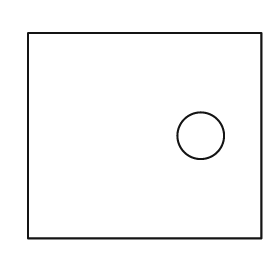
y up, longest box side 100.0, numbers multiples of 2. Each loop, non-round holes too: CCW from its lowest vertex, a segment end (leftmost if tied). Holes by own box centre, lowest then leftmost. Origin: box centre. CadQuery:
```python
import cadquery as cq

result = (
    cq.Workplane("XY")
    .moveTo(-50.0, -44.0)
    .lineTo(50.0, -44.0)
    .lineTo(50.0, 44.0)
    .lineTo(-50.0, 44.0)
    .close()
    .moveTo(24.0, 0.0)
    .circle(10.0)
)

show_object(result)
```